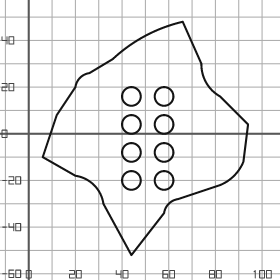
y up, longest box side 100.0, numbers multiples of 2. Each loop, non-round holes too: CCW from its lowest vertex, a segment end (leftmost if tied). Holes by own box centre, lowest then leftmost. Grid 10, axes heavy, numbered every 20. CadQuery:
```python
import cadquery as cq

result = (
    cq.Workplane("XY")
    .moveTo(44.0, -52.0)
    .lineTo(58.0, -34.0)
    .threePointArc((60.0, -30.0), (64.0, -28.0))
    .lineTo(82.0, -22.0)
    .threePointArc((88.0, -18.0), (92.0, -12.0))
    .lineTo(94.0, 4.0)
    .lineTo(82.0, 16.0)
    .threePointArc((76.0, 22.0), (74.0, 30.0))
    .lineTo(66.0, 48.0)
    .threePointArc((50.0, 42.0), (36.0, 32.0))
    .lineTo(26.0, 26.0)
    .threePointArc((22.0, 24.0), (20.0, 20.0))
    .lineTo(12.0, 8.0)
    .lineTo(6.0, -10.0)
    .lineTo(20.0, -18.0)
    .threePointArc((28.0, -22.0), (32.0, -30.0))
    .close()
    .moveTo(44.0, -20.0)
    .circle(4.0)
    .moveTo(58.0, -20.0)
    .circle(4.0)
    .moveTo(44.0, -8.0)
    .circle(4.0)
    .moveTo(58.0, -8.0)
    .circle(4.0)
    .moveTo(44.0, 4.0)
    .circle(4.0)
    .moveTo(58.0, 4.0)
    .circle(4.0)
    .moveTo(44.0, 16.0)
    .circle(4.0)
    .moveTo(58.0, 16.0)
    .circle(4.0)
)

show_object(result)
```